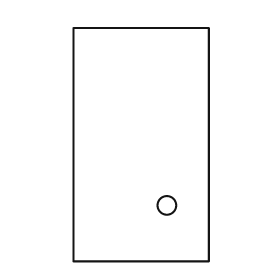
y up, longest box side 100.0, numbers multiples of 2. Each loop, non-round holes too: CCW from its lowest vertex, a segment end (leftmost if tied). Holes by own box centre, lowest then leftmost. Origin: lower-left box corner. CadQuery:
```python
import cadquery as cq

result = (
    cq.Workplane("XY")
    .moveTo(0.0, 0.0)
    .lineTo(58.0, 0.0)
    .lineTo(58.0, 100.0)
    .lineTo(0.0, 100.0)
    .close()
    .moveTo(40.0, 24.0)
    .circle(4.0)
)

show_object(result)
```